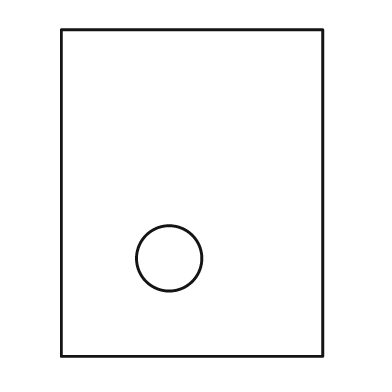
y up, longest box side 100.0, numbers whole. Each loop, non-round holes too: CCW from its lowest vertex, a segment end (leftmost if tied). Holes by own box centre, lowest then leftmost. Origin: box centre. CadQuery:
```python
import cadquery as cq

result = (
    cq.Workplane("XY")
    .moveTo(-40.0, -50.0)
    .lineTo(40.0, -50.0)
    .lineTo(40.0, 50.0)
    .lineTo(-40.0, 50.0)
    .close()
    .moveTo(-7.0, -20.0)
    .circle(10.0)
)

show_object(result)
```